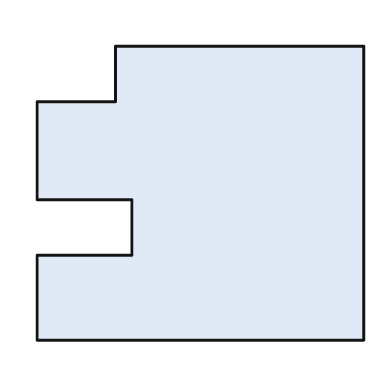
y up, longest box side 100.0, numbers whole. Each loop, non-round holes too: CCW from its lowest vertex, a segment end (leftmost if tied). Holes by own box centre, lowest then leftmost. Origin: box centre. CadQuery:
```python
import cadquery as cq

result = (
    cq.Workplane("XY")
    .moveTo(-50.0, -45.0)
    .lineTo(50.0, -45.0)
    .lineTo(50.0, 45.0)
    .lineTo(-26.0, 45.0)
    .lineTo(-26.0, 28.0)
    .lineTo(-50.0, 28.0)
    .lineTo(-50.0, -2.0)
    .lineTo(-21.0, -2.0)
    .lineTo(-21.0, -19.0)
    .lineTo(-50.0, -19.0)
    .close()
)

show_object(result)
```